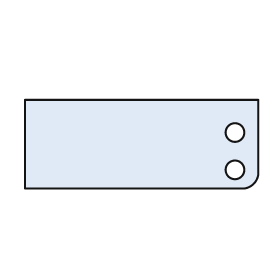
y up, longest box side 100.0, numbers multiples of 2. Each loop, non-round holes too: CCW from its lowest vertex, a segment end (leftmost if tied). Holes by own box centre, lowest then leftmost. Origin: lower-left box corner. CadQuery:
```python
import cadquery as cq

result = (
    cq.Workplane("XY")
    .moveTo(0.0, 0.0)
    .lineTo(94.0, 0.0)
    .threePointArc((98.0, 2.0), (100.0, 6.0))
    .lineTo(100.0, 38.0)
    .lineTo(0.0, 38.0)
    .close()
    .moveTo(90.0, 8.0)
    .circle(4.0)
    .moveTo(90.0, 24.0)
    .circle(4.0)
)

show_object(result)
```